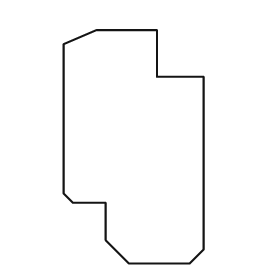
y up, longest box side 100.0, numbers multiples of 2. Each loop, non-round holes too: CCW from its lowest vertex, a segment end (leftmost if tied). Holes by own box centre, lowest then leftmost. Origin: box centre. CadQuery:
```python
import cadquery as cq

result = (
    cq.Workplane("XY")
    .moveTo(-2.0, -50.0)
    .lineTo(24.0, -50.0)
    .lineTo(30.0, -44.0)
    .lineTo(30.0, 30.0)
    .lineTo(10.0, 30.0)
    .lineTo(10.0, 50.0)
    .lineTo(-16.0, 50.0)
    .lineTo(-30.0, 44.0)
    .lineTo(-30.0, -20.0)
    .lineTo(-26.0, -24.0)
    .lineTo(-12.0, -24.0)
    .lineTo(-12.0, -40.0)
    .close()
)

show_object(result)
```